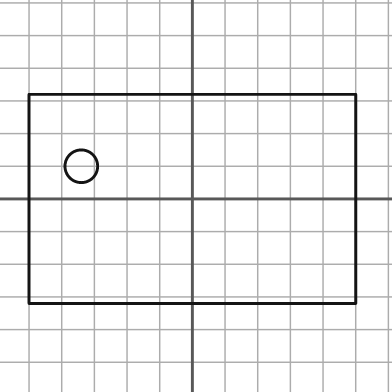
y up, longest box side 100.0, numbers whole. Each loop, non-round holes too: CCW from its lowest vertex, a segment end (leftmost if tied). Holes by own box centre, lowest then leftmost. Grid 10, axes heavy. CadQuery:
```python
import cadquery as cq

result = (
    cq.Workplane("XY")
    .moveTo(-50.0, -32.0)
    .lineTo(50.0, -32.0)
    .lineTo(50.0, 32.0)
    .lineTo(-50.0, 32.0)
    .close()
    .moveTo(-34.0, 10.0)
    .circle(5.0)
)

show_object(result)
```